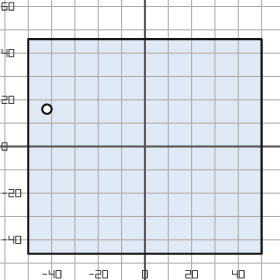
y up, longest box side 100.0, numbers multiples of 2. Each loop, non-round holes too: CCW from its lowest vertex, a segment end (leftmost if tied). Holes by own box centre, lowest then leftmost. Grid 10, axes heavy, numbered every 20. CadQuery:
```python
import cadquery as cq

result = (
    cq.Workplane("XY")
    .moveTo(-50.0, -46.0)
    .lineTo(50.0, -46.0)
    .lineTo(50.0, 46.0)
    .lineTo(-50.0, 46.0)
    .close()
    .moveTo(-42.0, 16.0)
    .circle(2.0)
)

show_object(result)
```